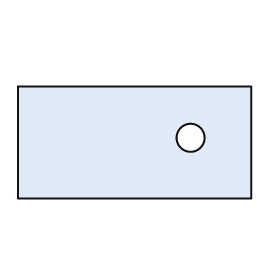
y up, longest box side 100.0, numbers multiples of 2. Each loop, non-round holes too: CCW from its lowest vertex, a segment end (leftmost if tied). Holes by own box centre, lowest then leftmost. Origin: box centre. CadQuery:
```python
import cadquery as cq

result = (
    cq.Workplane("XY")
    .moveTo(-50.0, -24.0)
    .lineTo(50.0, -24.0)
    .lineTo(50.0, 24.0)
    .lineTo(-50.0, 24.0)
    .close()
    .moveTo(24.0, 2.0)
    .circle(6.0)
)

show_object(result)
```